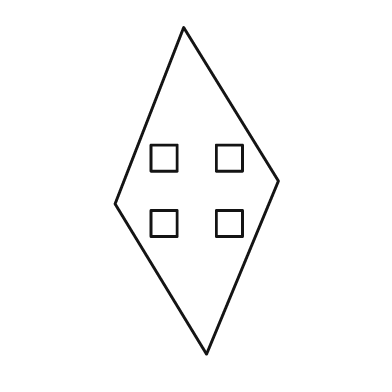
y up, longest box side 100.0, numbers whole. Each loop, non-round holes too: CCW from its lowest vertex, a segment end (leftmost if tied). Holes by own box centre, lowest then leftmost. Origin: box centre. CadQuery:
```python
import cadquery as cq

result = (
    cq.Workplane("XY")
    .moveTo(3.0, -50.0)
    .lineTo(25.0, 3.0)
    .lineTo(-4.0, 50.0)
    .lineTo(-25.0, -4.0)
    .close()
    .moveTo(-14.0, -14.0)
    .lineTo(-6.0, -14.0)
    .lineTo(-6.0, -6.0)
    .lineTo(-14.0, -6.0)
    .close()
    .moveTo(6.0, -14.0)
    .lineTo(14.0, -14.0)
    .lineTo(14.0, -6.0)
    .lineTo(6.0, -6.0)
    .close()
    .moveTo(-14.0, 6.0)
    .lineTo(-6.0, 6.0)
    .lineTo(-6.0, 14.0)
    .lineTo(-14.0, 14.0)
    .close()
    .moveTo(6.0, 6.0)
    .lineTo(14.0, 6.0)
    .lineTo(14.0, 14.0)
    .lineTo(6.0, 14.0)
    .close()
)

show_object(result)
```